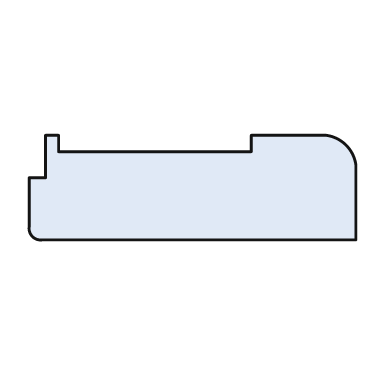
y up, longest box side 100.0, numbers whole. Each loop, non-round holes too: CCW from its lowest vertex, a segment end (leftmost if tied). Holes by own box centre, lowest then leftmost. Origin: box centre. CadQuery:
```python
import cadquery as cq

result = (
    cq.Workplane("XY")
    .moveTo(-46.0, -16.0)
    .lineTo(50.0, -16.0)
    .lineTo(50.0, 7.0)
    .threePointArc((47.0, 13.0), (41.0, 16.0))
    .lineTo(18.0, 16.0)
    .lineTo(18.0, 11.0)
    .lineTo(-41.0, 11.0)
    .lineTo(-41.0, 16.0)
    .lineTo(-45.0, 16.0)
    .lineTo(-45.0, 3.0)
    .lineTo(-50.0, 3.0)
    .lineTo(-50.0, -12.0)
    .threePointArc((-49.0, -15.0), (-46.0, -16.0))
    .close()
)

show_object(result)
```